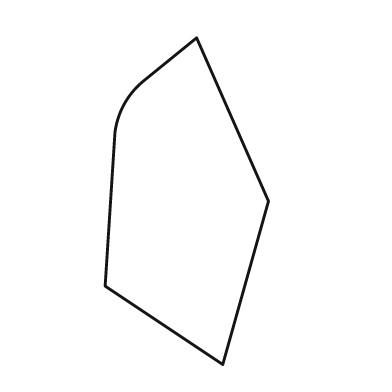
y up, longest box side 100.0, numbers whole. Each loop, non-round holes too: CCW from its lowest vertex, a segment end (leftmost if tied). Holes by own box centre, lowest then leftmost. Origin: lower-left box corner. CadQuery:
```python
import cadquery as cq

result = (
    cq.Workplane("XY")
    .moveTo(36.0, 0.0)
    .lineTo(50.0, 50.0)
    .lineTo(28.0, 100.0)
    .lineTo(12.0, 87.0)
    .threePointArc((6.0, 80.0), (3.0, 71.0))
    .lineTo(0.0, 24.0)
    .close()
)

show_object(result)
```